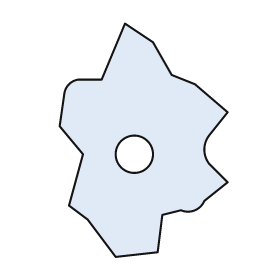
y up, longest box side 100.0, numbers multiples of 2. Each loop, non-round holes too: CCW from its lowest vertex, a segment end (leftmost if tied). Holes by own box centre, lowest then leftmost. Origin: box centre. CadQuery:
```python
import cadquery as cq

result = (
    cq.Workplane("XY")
    .moveTo(-12.0, -50.0)
    .lineTo(6.0, -48.0)
    .lineTo(8.0, -32.0)
    .lineTo(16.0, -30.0)
    .threePointArc((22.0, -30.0), (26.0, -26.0))
    .lineTo(36.0, -18.0)
    .lineTo(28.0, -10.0)
    .threePointArc((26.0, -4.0), (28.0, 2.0))
    .lineTo(36.0, 12.0)
    .lineTo(22.0, 24.0)
    .lineTo(12.0, 28.0)
    .lineTo(4.0, 42.0)
    .lineTo(-8.0, 50.0)
    .lineTo(-18.0, 26.0)
    .lineTo(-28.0, 26.0)
    .threePointArc((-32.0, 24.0), (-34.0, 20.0))
    .lineTo(-36.0, 6.0)
    .lineTo(-26.0, -6.0)
    .lineTo(-32.0, -28.0)
    .lineTo(-24.0, -34.0)
    .close()
    .moveTo(-4.0, -6.0)
    .circle(8.0)
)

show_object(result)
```